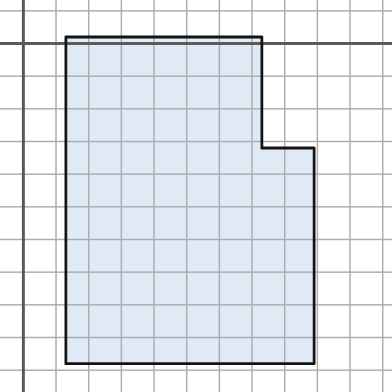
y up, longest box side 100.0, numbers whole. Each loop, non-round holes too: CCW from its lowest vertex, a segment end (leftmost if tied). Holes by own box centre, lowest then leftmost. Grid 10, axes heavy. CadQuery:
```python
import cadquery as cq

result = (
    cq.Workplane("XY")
    .moveTo(13.0, -98.0)
    .lineTo(89.0, -98.0)
    .lineTo(89.0, -32.0)
    .lineTo(73.0, -32.0)
    .lineTo(73.0, 2.0)
    .lineTo(13.0, 2.0)
    .close()
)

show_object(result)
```